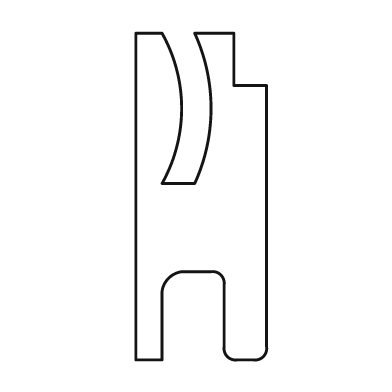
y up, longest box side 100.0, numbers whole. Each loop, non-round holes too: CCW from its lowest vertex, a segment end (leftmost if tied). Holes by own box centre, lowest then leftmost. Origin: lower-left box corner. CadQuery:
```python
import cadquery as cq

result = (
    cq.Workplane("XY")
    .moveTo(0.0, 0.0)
    .lineTo(8.0, 0.0)
    .lineTo(8.0, 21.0)
    .threePointArc((10.0, 25.0), (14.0, 27.0))
    .lineTo(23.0, 27.0)
    .threePointArc((26.0, 26.0), (27.0, 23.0))
    .lineTo(27.0, 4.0)
    .threePointArc((28.0, 1.0), (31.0, 0.0))
    .lineTo(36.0, 0.0)
    .threePointArc((39.0, 1.0), (40.0, 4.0))
    .lineTo(40.0, 84.0)
    .lineTo(30.0, 84.0)
    .lineTo(30.0, 100.0)
    .lineTo(18.0, 100.0)
    .threePointArc((23.0, 77.0), (18.0, 54.0))
    .lineTo(8.0, 54.0)
    .threePointArc((14.0, 77.0), (8.0, 100.0))
    .lineTo(0.0, 100.0)
    .close()
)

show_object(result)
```